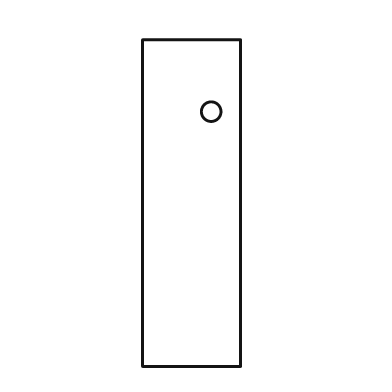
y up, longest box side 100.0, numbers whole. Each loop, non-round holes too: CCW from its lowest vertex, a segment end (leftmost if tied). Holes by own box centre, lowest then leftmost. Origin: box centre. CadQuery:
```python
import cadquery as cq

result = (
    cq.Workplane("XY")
    .moveTo(-15.0, -50.0)
    .lineTo(15.0, -50.0)
    .lineTo(15.0, 50.0)
    .lineTo(-15.0, 50.0)
    .close()
    .moveTo(6.0, 28.0)
    .circle(3.0)
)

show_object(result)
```